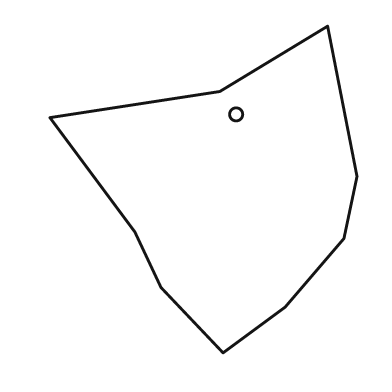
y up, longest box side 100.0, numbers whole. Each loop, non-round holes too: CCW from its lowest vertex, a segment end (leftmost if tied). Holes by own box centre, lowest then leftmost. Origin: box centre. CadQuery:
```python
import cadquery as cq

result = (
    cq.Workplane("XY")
    .moveTo(6.0, -50.0)
    .lineTo(25.0, -36.0)
    .lineTo(43.0, -15.0)
    .lineTo(47.0, 4.0)
    .lineTo(38.0, 50.0)
    .lineTo(5.0, 30.0)
    .lineTo(-47.0, 22.0)
    .lineTo(-21.0, -13.0)
    .lineTo(-13.0, -30.0)
    .close()
    .moveTo(10.0, 23.0)
    .circle(2.0)
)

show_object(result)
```